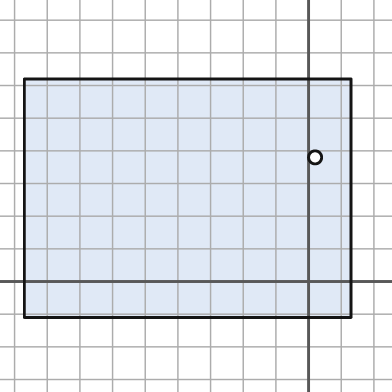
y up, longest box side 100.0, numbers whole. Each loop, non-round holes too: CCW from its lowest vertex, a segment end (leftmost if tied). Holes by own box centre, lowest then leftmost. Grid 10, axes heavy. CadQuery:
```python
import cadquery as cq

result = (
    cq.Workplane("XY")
    .moveTo(-87.0, -11.0)
    .lineTo(13.0, -11.0)
    .lineTo(13.0, 62.0)
    .lineTo(-87.0, 62.0)
    .close()
    .moveTo(2.0, 38.0)
    .circle(2.0)
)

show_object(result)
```